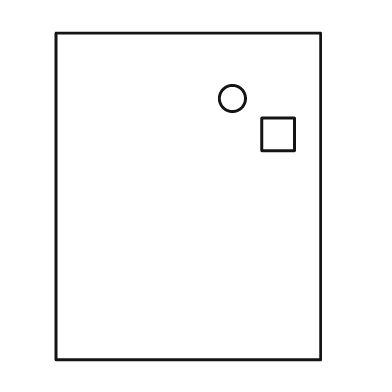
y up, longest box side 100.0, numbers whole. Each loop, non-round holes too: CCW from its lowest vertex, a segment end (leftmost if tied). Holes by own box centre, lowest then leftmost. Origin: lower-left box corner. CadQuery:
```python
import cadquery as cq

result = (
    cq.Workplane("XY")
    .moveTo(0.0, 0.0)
    .lineTo(81.0, 0.0)
    .lineTo(81.0, 100.0)
    .lineTo(0.0, 100.0)
    .close()
    .moveTo(63.0, 64.0)
    .lineTo(73.0, 64.0)
    .lineTo(73.0, 74.0)
    .lineTo(63.0, 74.0)
    .close()
    .moveTo(54.0, 80.0)
    .circle(4.0)
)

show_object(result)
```